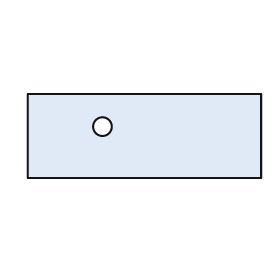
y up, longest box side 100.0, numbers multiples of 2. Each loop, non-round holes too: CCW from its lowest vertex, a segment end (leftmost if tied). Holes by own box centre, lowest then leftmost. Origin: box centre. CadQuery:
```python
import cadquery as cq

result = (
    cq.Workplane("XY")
    .moveTo(-50.0, -18.0)
    .lineTo(50.0, -18.0)
    .lineTo(50.0, 18.0)
    .lineTo(-50.0, 18.0)
    .close()
    .moveTo(-18.0, 4.0)
    .circle(4.0)
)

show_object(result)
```